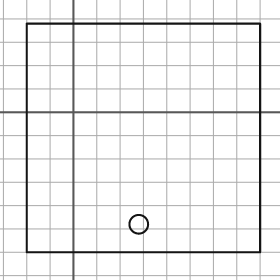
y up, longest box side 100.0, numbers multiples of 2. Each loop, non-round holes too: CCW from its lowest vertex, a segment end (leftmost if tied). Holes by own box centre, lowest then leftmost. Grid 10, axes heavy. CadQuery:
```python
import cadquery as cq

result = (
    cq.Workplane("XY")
    .moveTo(-20.0, -60.0)
    .lineTo(80.0, -60.0)
    .lineTo(80.0, 38.0)
    .lineTo(-20.0, 38.0)
    .close()
    .moveTo(28.0, -48.0)
    .circle(4.0)
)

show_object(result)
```